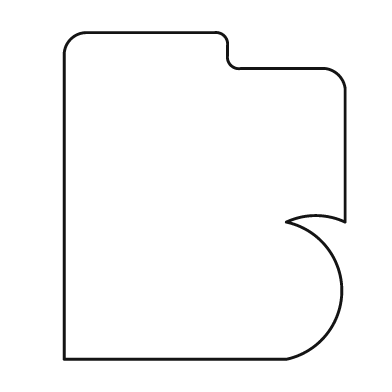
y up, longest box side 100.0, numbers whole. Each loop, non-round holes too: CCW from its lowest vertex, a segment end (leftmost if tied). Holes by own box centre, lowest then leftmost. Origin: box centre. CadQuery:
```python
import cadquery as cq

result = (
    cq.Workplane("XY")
    .moveTo(-43.0, -50.0)
    .lineTo(25.0, -50.0)
    .threePointArc((42.0, -29.0), (25.0, -8.0))
    .threePointArc((34.0, -6.0), (43.0, -8.0))
    .lineTo(43.0, 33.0)
    .threePointArc((41.0, 37.0), (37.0, 39.0))
    .lineTo(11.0, 39.0)
    .threePointArc((8.0, 40.0), (7.0, 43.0))
    .lineTo(7.0, 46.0)
    .threePointArc((6.0, 49.0), (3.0, 50.0))
    .lineTo(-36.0, 50.0)
    .threePointArc((-41.0, 48.0), (-43.0, 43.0))
    .close()
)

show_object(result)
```